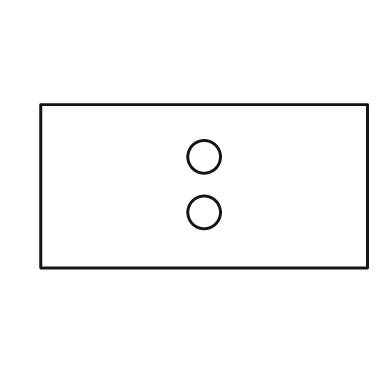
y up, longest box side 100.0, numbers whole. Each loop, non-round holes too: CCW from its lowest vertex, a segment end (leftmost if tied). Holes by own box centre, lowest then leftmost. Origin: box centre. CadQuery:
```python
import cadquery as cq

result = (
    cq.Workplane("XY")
    .moveTo(-50.0, -25.0)
    .lineTo(50.0, -25.0)
    .lineTo(50.0, 25.0)
    .lineTo(-50.0, 25.0)
    .close()
    .moveTo(0.0, -8.0)
    .circle(5.0)
    .moveTo(0.0, 9.0)
    .circle(5.0)
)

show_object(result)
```